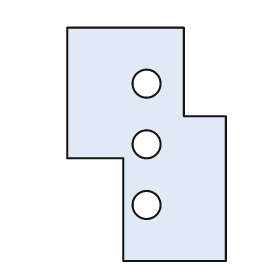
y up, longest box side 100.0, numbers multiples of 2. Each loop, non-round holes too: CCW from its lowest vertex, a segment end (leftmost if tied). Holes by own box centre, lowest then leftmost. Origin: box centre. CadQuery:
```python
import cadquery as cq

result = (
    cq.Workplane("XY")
    .moveTo(-10.0, -50.0)
    .lineTo(34.0, -50.0)
    .lineTo(34.0, 12.0)
    .lineTo(16.0, 12.0)
    .lineTo(16.0, 50.0)
    .lineTo(-34.0, 50.0)
    .lineTo(-34.0, -6.0)
    .lineTo(-10.0, -6.0)
    .close()
    .moveTo(0.0, -26.0)
    .circle(6.0)
    .moveTo(0.0, 0.0)
    .circle(6.0)
    .moveTo(0.0, 26.0)
    .circle(6.0)
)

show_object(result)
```